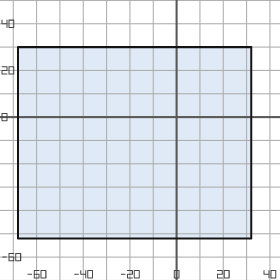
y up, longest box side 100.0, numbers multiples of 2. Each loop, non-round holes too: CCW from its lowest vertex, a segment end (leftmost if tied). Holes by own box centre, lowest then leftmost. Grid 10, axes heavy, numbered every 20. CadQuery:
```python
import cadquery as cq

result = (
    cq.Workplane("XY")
    .moveTo(-68.0, -52.0)
    .lineTo(32.0, -52.0)
    .lineTo(32.0, 30.0)
    .lineTo(-68.0, 30.0)
    .close()
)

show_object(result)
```